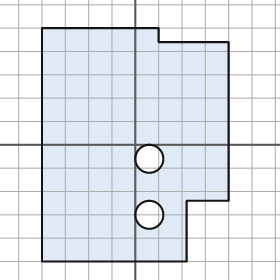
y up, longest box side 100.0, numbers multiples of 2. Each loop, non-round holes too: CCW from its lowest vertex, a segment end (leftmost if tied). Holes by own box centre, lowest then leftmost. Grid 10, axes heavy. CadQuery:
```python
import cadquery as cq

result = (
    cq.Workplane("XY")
    .moveTo(-40.0, -50.0)
    .lineTo(22.0, -50.0)
    .lineTo(22.0, -24.0)
    .lineTo(40.0, -24.0)
    .lineTo(40.0, 44.0)
    .lineTo(10.0, 44.0)
    .lineTo(10.0, 50.0)
    .lineTo(-40.0, 50.0)
    .close()
    .moveTo(6.0, -30.0)
    .circle(6.0)
    .moveTo(6.0, -6.0)
    .circle(6.0)
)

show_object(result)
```